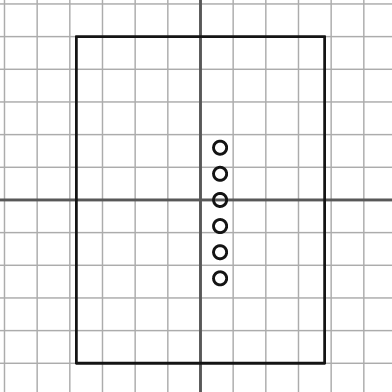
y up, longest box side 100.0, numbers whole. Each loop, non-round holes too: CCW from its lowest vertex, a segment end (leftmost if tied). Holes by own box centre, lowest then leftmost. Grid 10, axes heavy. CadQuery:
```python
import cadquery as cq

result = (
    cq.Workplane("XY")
    .moveTo(-38.0, -50.0)
    .lineTo(38.0, -50.0)
    .lineTo(38.0, 50.0)
    .lineTo(-38.0, 50.0)
    .close()
    .moveTo(6.0, -24.0)
    .circle(2.0)
    .moveTo(6.0, -16.0)
    .circle(2.0)
    .moveTo(6.0, -8.0)
    .circle(2.0)
    .moveTo(6.0, 0.0)
    .circle(2.0)
    .moveTo(6.0, 8.0)
    .circle(2.0)
    .moveTo(6.0, 16.0)
    .circle(2.0)
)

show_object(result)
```